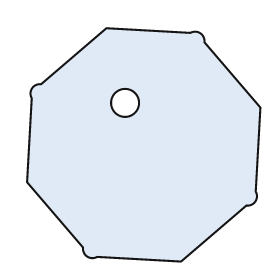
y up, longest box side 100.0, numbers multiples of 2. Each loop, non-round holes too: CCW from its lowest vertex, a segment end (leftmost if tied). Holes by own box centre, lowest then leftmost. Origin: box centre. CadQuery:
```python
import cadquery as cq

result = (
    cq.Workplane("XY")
    .moveTo(16.0, -50.0)
    .lineTo(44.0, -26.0)
    .threePointArc((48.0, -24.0), (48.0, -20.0))
    .lineTo(50.0, 16.0)
    .lineTo(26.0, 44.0)
    .threePointArc((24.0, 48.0), (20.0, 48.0))
    .lineTo(-16.0, 50.0)
    .lineTo(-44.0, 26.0)
    .threePointArc((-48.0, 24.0), (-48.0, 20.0))
    .lineTo(-50.0, -16.0)
    .lineTo(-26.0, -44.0)
    .threePointArc((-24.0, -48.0), (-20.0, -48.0))
    .close()
    .moveTo(-8.0, 18.0)
    .circle(6.0)
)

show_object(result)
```